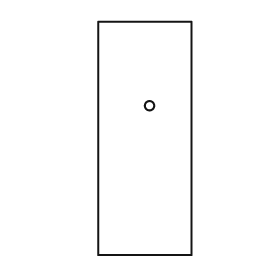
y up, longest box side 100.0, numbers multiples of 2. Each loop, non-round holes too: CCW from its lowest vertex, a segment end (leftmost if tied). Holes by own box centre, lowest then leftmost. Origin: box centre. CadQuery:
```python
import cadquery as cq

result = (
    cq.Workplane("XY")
    .moveTo(-20.0, -50.0)
    .lineTo(20.0, -50.0)
    .lineTo(20.0, 50.0)
    .lineTo(-20.0, 50.0)
    .close()
    .moveTo(2.0, 14.0)
    .circle(2.0)
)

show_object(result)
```